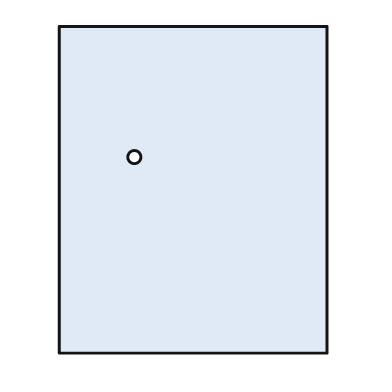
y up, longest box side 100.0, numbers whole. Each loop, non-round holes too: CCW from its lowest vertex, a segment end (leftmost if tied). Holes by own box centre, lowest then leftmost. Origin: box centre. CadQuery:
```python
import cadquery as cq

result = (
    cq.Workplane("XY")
    .moveTo(-41.0, -50.0)
    .lineTo(41.0, -50.0)
    .lineTo(41.0, 50.0)
    .lineTo(-41.0, 50.0)
    .close()
    .moveTo(-18.0, 10.0)
    .circle(2.0)
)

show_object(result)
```